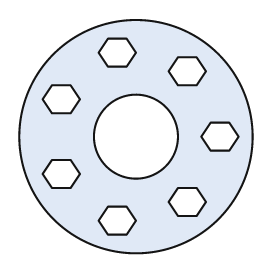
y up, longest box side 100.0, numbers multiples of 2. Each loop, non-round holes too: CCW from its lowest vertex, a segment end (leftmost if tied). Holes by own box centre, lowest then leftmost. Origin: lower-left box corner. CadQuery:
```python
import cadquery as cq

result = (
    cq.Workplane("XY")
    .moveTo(50.0, 50.0)
    .circle(50.0)
    .moveTo(38.0, 8.0)
    .lineTo(46.0, 8.0)
    .lineTo(50.0, 14.0)
    .lineTo(46.0, 20.0)
    .lineTo(38.0, 20.0)
    .lineTo(34.0, 14.0)
    .close()
    .moveTo(68.0, 16.0)
    .lineTo(76.0, 16.0)
    .lineTo(80.0, 22.0)
    .lineTo(76.0, 28.0)
    .lineTo(68.0, 28.0)
    .lineTo(64.0, 22.0)
    .close()
    .moveTo(14.0, 28.0)
    .lineTo(22.0, 28.0)
    .lineTo(26.0, 34.0)
    .lineTo(22.0, 40.0)
    .lineTo(14.0, 40.0)
    .lineTo(10.0, 34.0)
    .close()
    .moveTo(50.0, 50.0)
    .circle(18.0)
    .moveTo(82.0, 44.0)
    .lineTo(90.0, 44.0)
    .lineTo(94.0, 50.0)
    .lineTo(90.0, 56.0)
    .lineTo(82.0, 56.0)
    .lineTo(78.0, 50.0)
    .close()
    .moveTo(14.0, 60.0)
    .lineTo(22.0, 60.0)
    .lineTo(26.0, 66.0)
    .lineTo(22.0, 72.0)
    .lineTo(14.0, 72.0)
    .lineTo(10.0, 66.0)
    .close()
    .moveTo(68.0, 72.0)
    .lineTo(76.0, 72.0)
    .lineTo(80.0, 78.0)
    .lineTo(76.0, 84.0)
    .lineTo(68.0, 84.0)
    .lineTo(64.0, 78.0)
    .close()
    .moveTo(38.0, 80.0)
    .lineTo(46.0, 80.0)
    .lineTo(50.0, 86.0)
    .lineTo(46.0, 92.0)
    .lineTo(38.0, 92.0)
    .lineTo(34.0, 86.0)
    .close()
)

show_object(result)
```